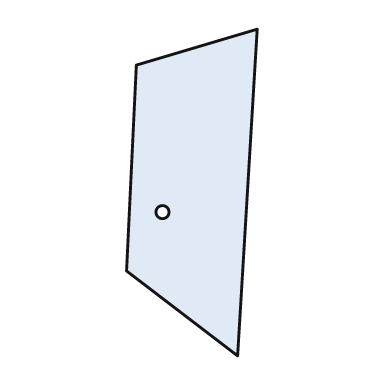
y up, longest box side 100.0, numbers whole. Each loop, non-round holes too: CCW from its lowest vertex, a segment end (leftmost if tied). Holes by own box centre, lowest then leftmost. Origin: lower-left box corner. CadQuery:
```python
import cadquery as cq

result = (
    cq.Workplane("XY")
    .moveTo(34.0, 0.0)
    .lineTo(40.0, 100.0)
    .lineTo(3.0, 89.0)
    .lineTo(0.0, 26.0)
    .close()
    .moveTo(11.0, 44.0)
    .circle(2.0)
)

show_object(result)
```